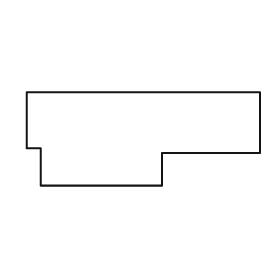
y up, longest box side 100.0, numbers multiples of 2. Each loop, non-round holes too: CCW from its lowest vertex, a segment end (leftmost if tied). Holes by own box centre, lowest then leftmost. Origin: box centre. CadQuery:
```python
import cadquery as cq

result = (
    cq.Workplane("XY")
    .moveTo(-44.0, -20.0)
    .lineTo(8.0, -20.0)
    .lineTo(8.0, -6.0)
    .lineTo(50.0, -6.0)
    .lineTo(50.0, 20.0)
    .lineTo(-50.0, 20.0)
    .lineTo(-50.0, -4.0)
    .lineTo(-44.0, -4.0)
    .close()
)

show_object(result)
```